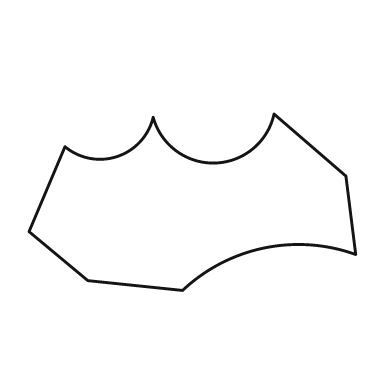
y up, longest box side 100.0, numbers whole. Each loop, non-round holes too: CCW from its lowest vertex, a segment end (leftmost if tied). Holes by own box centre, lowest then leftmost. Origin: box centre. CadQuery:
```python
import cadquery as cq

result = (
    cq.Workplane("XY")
    .moveTo(-3.0, -27.0)
    .threePointArc((22.0, -14.0), (50.0, -16.0))
    .lineTo(47.0, 8.0)
    .lineTo(25.0, 27.0)
    .threePointArc((7.0, 12.0), (-12.0, 26.0))
    .threePointArc((-23.0, 14.0), (-39.0, 17.0))
    .lineTo(-50.0, -9.0)
    .lineTo(-32.0, -24.0)
    .close()
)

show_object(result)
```